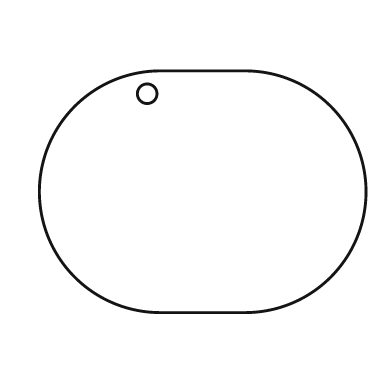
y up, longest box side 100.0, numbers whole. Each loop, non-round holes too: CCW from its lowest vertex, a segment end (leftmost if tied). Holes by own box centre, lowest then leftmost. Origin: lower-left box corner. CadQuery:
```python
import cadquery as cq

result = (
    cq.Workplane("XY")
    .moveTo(37.0, 0.0)
    .lineTo(63.0, 0.0)
    .threePointArc((100.0, 37.0), (63.0, 74.0))
    .lineTo(37.0, 74.0)
    .threePointArc((0.0, 37.0), (37.0, 0.0))
    .close()
    .moveTo(33.0, 67.0)
    .circle(3.0)
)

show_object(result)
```